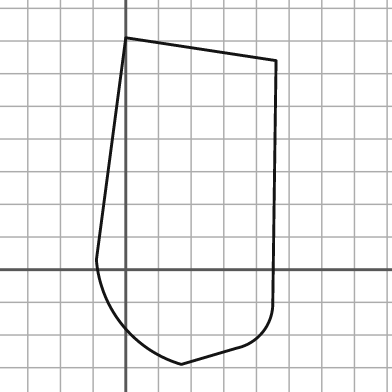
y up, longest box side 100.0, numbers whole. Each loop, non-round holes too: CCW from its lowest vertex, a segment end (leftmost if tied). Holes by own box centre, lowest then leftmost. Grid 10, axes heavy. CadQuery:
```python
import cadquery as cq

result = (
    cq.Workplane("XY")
    .moveTo(17.0, -29.0)
    .lineTo(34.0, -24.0)
    .threePointArc((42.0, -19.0), (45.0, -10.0))
    .lineTo(46.0, 64.0)
    .lineTo(0.0, 71.0)
    .lineTo(-9.0, 3.0)
    .threePointArc((-1.0, -17.0), (17.0, -29.0))
    .close()
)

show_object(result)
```